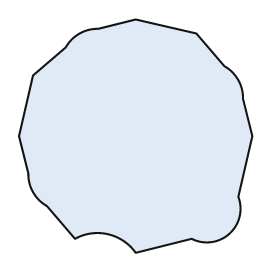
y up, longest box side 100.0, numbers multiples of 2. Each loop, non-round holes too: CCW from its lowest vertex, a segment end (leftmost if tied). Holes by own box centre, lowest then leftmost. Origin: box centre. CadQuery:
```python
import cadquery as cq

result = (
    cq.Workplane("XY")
    .moveTo(0.0, -50.0)
    .lineTo(24.0, -44.0)
    .threePointArc((40.0, -42.0), (44.0, -26.0))
    .lineTo(50.0, 0.0)
    .lineTo(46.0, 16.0)
    .threePointArc((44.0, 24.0), (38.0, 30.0))
    .lineTo(26.0, 44.0)
    .lineTo(0.0, 50.0)
    .lineTo(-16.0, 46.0)
    .threePointArc((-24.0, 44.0), (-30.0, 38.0))
    .lineTo(-44.0, 26.0)
    .lineTo(-50.0, 0.0)
    .lineTo(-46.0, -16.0)
    .threePointArc((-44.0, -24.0), (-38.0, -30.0))
    .lineTo(-26.0, -44.0)
    .threePointArc((-12.0, -42.0), (0.0, -50.0))
    .close()
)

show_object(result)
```